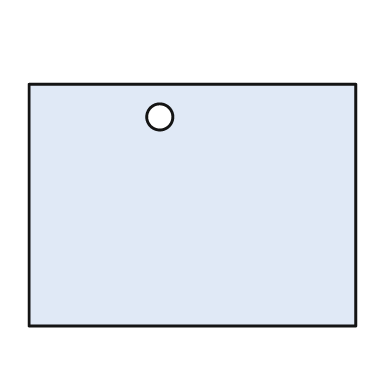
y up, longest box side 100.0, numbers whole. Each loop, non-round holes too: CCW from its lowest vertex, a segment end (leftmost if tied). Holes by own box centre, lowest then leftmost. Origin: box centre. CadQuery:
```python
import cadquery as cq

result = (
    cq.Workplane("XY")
    .moveTo(-50.0, -37.0)
    .lineTo(50.0, -37.0)
    .lineTo(50.0, 37.0)
    .lineTo(-50.0, 37.0)
    .close()
    .moveTo(-10.0, 27.0)
    .circle(4.0)
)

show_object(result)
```